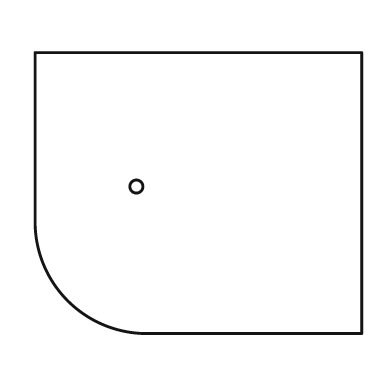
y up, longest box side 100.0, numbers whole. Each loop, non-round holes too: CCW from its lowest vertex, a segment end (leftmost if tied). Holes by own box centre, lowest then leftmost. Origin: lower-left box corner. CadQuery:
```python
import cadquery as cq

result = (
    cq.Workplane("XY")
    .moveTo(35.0, 0.0)
    .lineTo(100.0, 0.0)
    .lineTo(100.0, 86.0)
    .lineTo(0.0, 86.0)
    .lineTo(0.0, 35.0)
    .threePointArc((10.0, 10.0), (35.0, 0.0))
    .close()
    .moveTo(31.0, 45.0)
    .circle(2.0)
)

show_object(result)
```